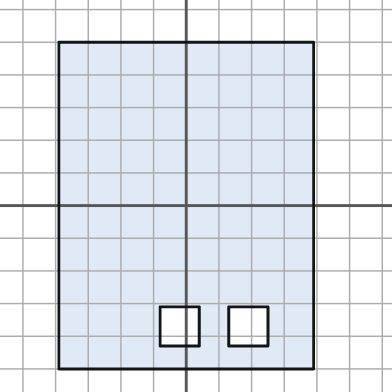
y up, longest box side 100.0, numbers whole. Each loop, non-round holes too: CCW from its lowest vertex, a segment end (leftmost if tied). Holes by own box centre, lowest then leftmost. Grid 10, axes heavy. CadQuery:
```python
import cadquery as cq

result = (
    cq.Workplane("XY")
    .moveTo(-39.0, -50.0)
    .lineTo(39.0, -50.0)
    .lineTo(39.0, 50.0)
    .lineTo(-39.0, 50.0)
    .close()
    .moveTo(-8.0, -43.0)
    .lineTo(4.0, -43.0)
    .lineTo(4.0, -31.0)
    .lineTo(-8.0, -31.0)
    .close()
    .moveTo(13.0, -43.0)
    .lineTo(25.0, -43.0)
    .lineTo(25.0, -31.0)
    .lineTo(13.0, -31.0)
    .close()
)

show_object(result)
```